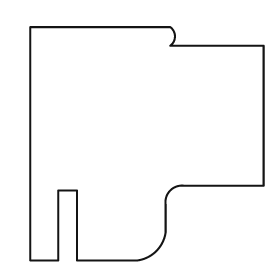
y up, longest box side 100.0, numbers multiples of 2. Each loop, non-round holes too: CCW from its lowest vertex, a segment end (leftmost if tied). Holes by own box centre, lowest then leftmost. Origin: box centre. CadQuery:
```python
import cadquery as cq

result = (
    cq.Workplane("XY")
    .moveTo(-50.0, -50.0)
    .lineTo(-38.0, -50.0)
    .lineTo(-38.0, -20.0)
    .lineTo(-30.0, -20.0)
    .lineTo(-30.0, -50.0)
    .lineTo(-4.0, -50.0)
    .threePointArc((4.0, -46.0), (8.0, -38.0))
    .lineTo(8.0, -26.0)
    .threePointArc((10.0, -20.0), (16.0, -18.0))
    .lineTo(50.0, -18.0)
    .lineTo(50.0, 42.0)
    .lineTo(10.0, 42.0)
    .threePointArc((12.0, 46.0), (10.0, 50.0))
    .lineTo(-50.0, 50.0)
    .close()
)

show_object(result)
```